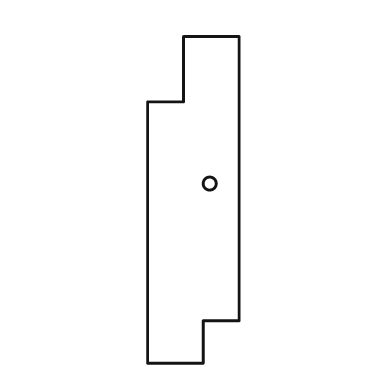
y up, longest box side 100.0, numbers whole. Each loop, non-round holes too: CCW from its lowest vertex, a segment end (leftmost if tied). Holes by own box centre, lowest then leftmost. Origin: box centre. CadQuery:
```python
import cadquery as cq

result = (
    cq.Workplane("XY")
    .moveTo(-14.0, -50.0)
    .lineTo(3.0, -50.0)
    .lineTo(3.0, -37.0)
    .lineTo(14.0, -37.0)
    .lineTo(14.0, 50.0)
    .lineTo(-3.0, 50.0)
    .lineTo(-3.0, 30.0)
    .lineTo(-14.0, 30.0)
    .close()
    .moveTo(5.0, 5.0)
    .circle(2.0)
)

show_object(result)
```